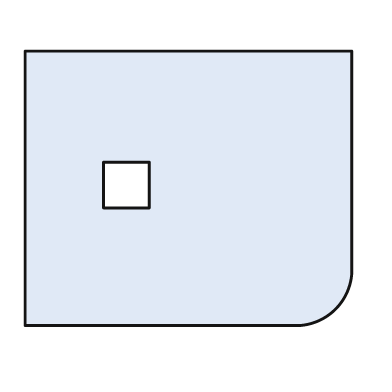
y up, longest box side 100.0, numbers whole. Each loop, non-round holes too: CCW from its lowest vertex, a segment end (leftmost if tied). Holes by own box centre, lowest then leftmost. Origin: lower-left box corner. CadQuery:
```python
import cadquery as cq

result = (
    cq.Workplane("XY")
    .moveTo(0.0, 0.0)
    .lineTo(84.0, 0.0)
    .threePointArc((95.0, 5.0), (100.0, 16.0))
    .lineTo(100.0, 84.0)
    .lineTo(0.0, 84.0)
    .close()
    .moveTo(24.0, 36.0)
    .lineTo(38.0, 36.0)
    .lineTo(38.0, 50.0)
    .lineTo(24.0, 50.0)
    .close()
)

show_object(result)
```